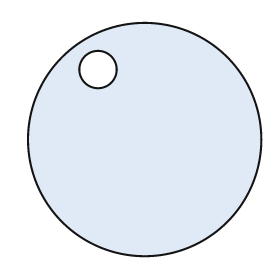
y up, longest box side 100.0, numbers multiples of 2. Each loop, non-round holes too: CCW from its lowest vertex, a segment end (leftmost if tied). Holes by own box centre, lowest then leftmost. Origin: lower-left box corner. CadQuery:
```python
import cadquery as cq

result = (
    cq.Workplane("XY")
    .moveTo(50.0, 50.0)
    .circle(50.0)
    .moveTo(30.0, 80.0)
    .circle(8.0)
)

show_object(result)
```